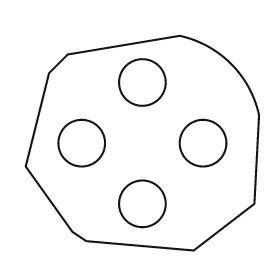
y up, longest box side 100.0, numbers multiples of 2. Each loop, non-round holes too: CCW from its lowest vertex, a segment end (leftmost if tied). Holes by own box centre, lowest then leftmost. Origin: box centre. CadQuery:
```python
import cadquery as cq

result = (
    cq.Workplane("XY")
    .moveTo(22.0, -46.0)
    .lineTo(48.0, -26.0)
    .lineTo(50.0, 12.0)
    .threePointArc((38.0, 34.0), (16.0, 46.0))
    .lineTo(-32.0, 38.0)
    .lineTo(-40.0, 30.0)
    .lineTo(-50.0, -10.0)
    .lineTo(-30.0, -38.0)
    .lineTo(-24.0, -42.0)
    .close()
    .moveTo(0.0, -26.0)
    .circle(10.0)
    .moveTo(-26.0, 0.0)
    .circle(10.0)
    .moveTo(26.0, 0.0)
    .circle(10.0)
    .moveTo(0.0, 26.0)
    .circle(10.0)
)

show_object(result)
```